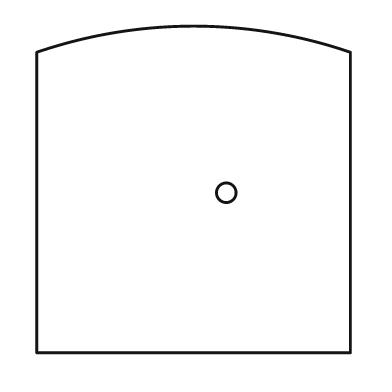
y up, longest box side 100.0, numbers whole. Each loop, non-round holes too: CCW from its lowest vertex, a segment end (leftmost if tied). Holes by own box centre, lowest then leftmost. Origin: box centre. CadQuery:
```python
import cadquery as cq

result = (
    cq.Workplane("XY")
    .moveTo(-48.0, -50.0)
    .lineTo(48.0, -50.0)
    .lineTo(48.0, 42.0)
    .threePointArc((0.0, 50.0), (-48.0, 42.0))
    .close()
    .moveTo(10.0, -1.0)
    .circle(3.0)
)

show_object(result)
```